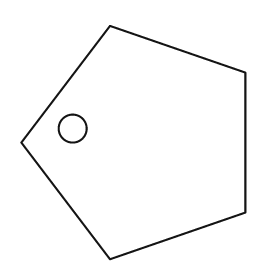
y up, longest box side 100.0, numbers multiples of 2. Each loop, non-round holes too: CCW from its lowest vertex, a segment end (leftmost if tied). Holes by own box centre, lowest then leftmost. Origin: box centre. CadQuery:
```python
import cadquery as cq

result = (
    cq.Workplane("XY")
    .moveTo(-10.0, -50.0)
    .lineTo(48.0, -30.0)
    .lineTo(48.0, 30.0)
    .lineTo(-10.0, 50.0)
    .lineTo(-48.0, 0.0)
    .close()
    .moveTo(-26.0, 6.0)
    .circle(6.0)
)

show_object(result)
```